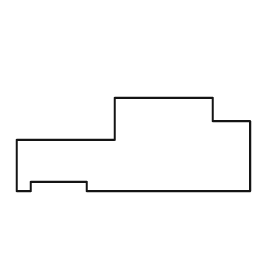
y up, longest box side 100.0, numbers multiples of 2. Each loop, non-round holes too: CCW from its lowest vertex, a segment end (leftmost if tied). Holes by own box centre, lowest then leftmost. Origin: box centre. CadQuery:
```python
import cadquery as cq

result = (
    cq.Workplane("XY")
    .moveTo(-50.0, -20.0)
    .lineTo(-44.0, -20.0)
    .lineTo(-44.0, -16.0)
    .lineTo(-20.0, -16.0)
    .lineTo(-20.0, -20.0)
    .lineTo(50.0, -20.0)
    .lineTo(50.0, 10.0)
    .lineTo(34.0, 10.0)
    .lineTo(34.0, 20.0)
    .lineTo(-8.0, 20.0)
    .lineTo(-8.0, 2.0)
    .lineTo(-50.0, 2.0)
    .close()
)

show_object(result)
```